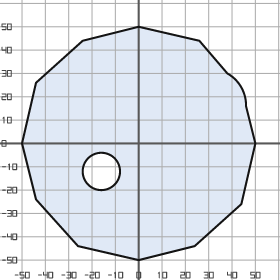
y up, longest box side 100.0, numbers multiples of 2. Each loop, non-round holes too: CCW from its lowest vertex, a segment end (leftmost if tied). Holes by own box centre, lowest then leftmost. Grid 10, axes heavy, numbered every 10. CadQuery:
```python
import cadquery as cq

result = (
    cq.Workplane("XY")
    .moveTo(0.0, -50.0)
    .lineTo(24.0, -44.0)
    .lineTo(44.0, -26.0)
    .lineTo(50.0, 0.0)
    .lineTo(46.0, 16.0)
    .threePointArc((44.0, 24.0), (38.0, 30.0))
    .lineTo(26.0, 44.0)
    .lineTo(0.0, 50.0)
    .lineTo(-24.0, 44.0)
    .lineTo(-44.0, 26.0)
    .lineTo(-50.0, 0.0)
    .lineTo(-44.0, -24.0)
    .lineTo(-26.0, -44.0)
    .close()
    .moveTo(-16.0, -12.0)
    .circle(8.0)
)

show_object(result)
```